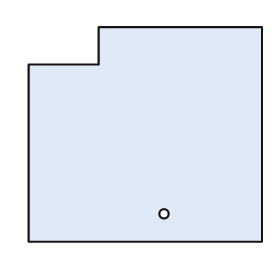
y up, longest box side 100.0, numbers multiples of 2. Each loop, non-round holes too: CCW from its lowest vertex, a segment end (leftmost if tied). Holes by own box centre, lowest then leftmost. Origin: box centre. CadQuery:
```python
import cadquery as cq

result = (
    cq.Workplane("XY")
    .moveTo(-50.0, -46.0)
    .lineTo(50.0, -46.0)
    .lineTo(50.0, 46.0)
    .lineTo(-20.0, 46.0)
    .lineTo(-20.0, 30.0)
    .lineTo(-50.0, 30.0)
    .close()
    .moveTo(8.0, -34.0)
    .circle(2.0)
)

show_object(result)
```